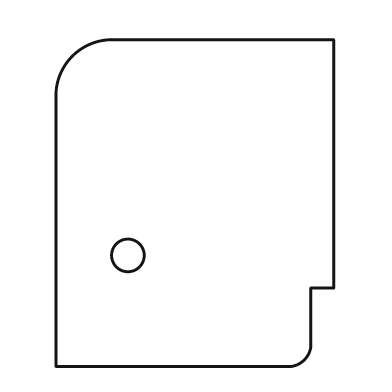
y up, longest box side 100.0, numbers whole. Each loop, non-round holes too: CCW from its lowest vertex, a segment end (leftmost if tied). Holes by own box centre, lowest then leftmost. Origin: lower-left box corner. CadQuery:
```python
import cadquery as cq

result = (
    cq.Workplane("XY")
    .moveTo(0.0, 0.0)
    .lineTo(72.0, 0.0)
    .threePointArc((76.0, 2.0), (78.0, 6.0))
    .lineTo(78.0, 24.0)
    .lineTo(85.0, 24.0)
    .lineTo(85.0, 100.0)
    .lineTo(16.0, 100.0)
    .threePointArc((5.0, 95.0), (0.0, 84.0))
    .close()
    .moveTo(22.0, 34.0)
    .circle(5.0)
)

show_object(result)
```